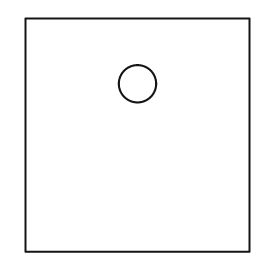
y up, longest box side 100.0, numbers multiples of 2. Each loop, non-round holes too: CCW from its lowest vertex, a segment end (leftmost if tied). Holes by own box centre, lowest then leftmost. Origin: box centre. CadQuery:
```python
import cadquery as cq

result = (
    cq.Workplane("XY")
    .moveTo(-48.0, -50.0)
    .lineTo(48.0, -50.0)
    .lineTo(48.0, 50.0)
    .lineTo(-48.0, 50.0)
    .close()
    .moveTo(0.0, 22.0)
    .circle(8.0)
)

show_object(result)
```